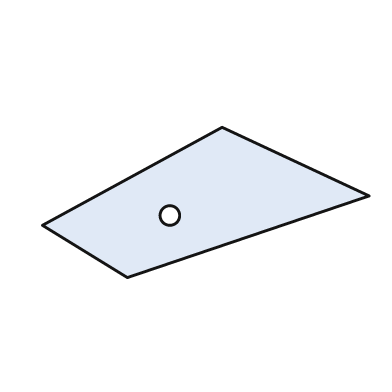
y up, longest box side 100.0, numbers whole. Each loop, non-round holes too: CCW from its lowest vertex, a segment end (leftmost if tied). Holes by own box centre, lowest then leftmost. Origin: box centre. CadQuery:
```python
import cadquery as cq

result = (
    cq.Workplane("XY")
    .moveTo(-24.0, -23.0)
    .lineTo(50.0, 2.0)
    .lineTo(5.0, 23.0)
    .lineTo(-50.0, -7.0)
    .close()
    .moveTo(-11.0, -4.0)
    .circle(3.0)
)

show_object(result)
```